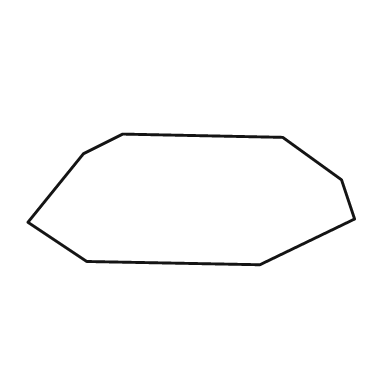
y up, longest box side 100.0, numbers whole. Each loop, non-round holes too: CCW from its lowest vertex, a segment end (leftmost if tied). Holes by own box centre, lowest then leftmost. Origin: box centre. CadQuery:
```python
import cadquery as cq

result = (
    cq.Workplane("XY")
    .moveTo(21.0, -20.0)
    .lineTo(50.0, -6.0)
    .lineTo(46.0, 6.0)
    .lineTo(28.0, 19.0)
    .lineTo(-21.0, 20.0)
    .lineTo(-33.0, 14.0)
    .lineTo(-50.0, -7.0)
    .lineTo(-32.0, -19.0)
    .close()
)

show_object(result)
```